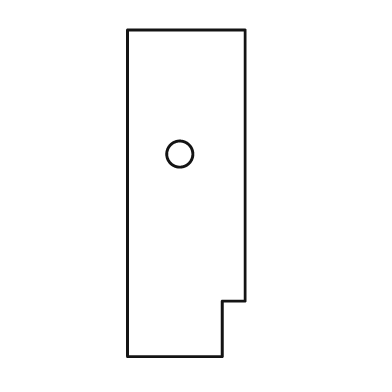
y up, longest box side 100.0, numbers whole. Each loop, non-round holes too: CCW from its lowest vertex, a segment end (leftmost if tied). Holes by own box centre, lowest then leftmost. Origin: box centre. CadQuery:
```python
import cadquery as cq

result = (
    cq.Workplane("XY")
    .moveTo(-18.0, -50.0)
    .lineTo(11.0, -50.0)
    .lineTo(11.0, -33.0)
    .lineTo(18.0, -33.0)
    .lineTo(18.0, 50.0)
    .lineTo(-18.0, 50.0)
    .close()
    .moveTo(-2.0, 12.0)
    .circle(4.0)
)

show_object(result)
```